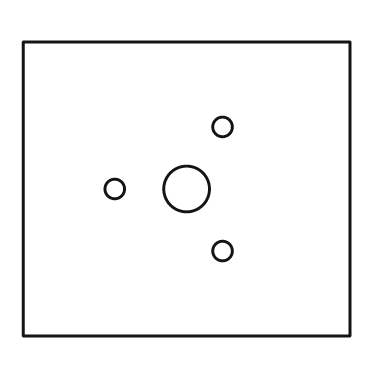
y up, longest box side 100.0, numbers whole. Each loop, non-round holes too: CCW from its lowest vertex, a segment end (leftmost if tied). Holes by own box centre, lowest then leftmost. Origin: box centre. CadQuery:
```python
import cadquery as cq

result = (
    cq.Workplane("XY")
    .moveTo(-50.0, -45.0)
    .lineTo(50.0, -45.0)
    .lineTo(50.0, 45.0)
    .lineTo(-50.0, 45.0)
    .close()
    .moveTo(11.0, -19.0)
    .circle(3.0)
    .moveTo(-22.0, 0.0)
    .circle(3.0)
    .moveTo(0.0, 0.0)
    .circle(7.0)
    .moveTo(11.0, 19.0)
    .circle(3.0)
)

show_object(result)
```